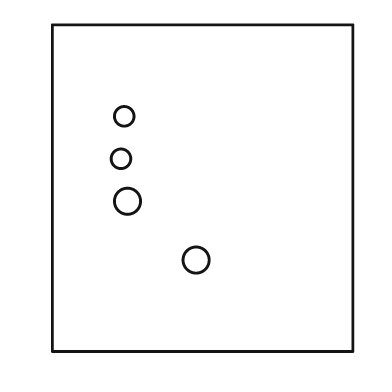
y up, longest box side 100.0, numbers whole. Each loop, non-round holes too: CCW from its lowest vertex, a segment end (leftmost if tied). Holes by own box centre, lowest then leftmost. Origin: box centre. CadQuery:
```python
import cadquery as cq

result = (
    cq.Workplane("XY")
    .moveTo(-46.0, -50.0)
    .lineTo(46.0, -50.0)
    .lineTo(46.0, 50.0)
    .lineTo(-46.0, 50.0)
    .close()
    .moveTo(-2.0, -22.0)
    .circle(4.0)
    .moveTo(-23.0, -4.0)
    .circle(4.0)
    .moveTo(-25.0, 9.0)
    .circle(3.0)
    .moveTo(-24.0, 22.0)
    .circle(3.0)
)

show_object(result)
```